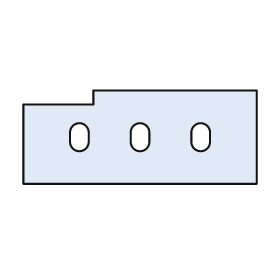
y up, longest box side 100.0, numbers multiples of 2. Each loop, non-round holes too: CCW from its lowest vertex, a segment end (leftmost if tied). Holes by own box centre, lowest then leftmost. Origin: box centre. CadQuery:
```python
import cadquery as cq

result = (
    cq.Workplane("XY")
    .moveTo(-50.0, -20.0)
    .lineTo(50.0, -20.0)
    .lineTo(50.0, 20.0)
    .lineTo(-20.0, 20.0)
    .lineTo(-20.0, 14.0)
    .lineTo(-50.0, 14.0)
    .close()
    .moveTo(-30.0, -2.0)
    .threePointArc((-26.0, -6.0), (-22.0, -2.0))
    .lineTo(-22.0, 2.0)
    .threePointArc((-26.0, 6.0), (-30.0, 2.0))
    .close()
    .moveTo(-4.0, -2.0)
    .threePointArc((0.0, -6.0), (4.0, -2.0))
    .lineTo(4.0, 2.0)
    .threePointArc((0.0, 6.0), (-4.0, 2.0))
    .close()
    .moveTo(22.0, -2.0)
    .threePointArc((26.0, -6.0), (30.0, -2.0))
    .lineTo(30.0, 2.0)
    .threePointArc((26.0, 6.0), (22.0, 2.0))
    .close()
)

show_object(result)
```